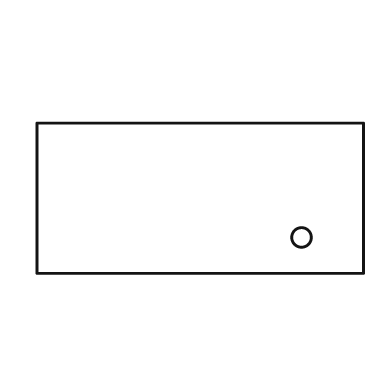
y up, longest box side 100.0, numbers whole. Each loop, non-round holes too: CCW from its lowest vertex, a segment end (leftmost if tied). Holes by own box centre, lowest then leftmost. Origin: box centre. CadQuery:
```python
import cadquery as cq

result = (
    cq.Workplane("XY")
    .moveTo(-50.0, -23.0)
    .lineTo(50.0, -23.0)
    .lineTo(50.0, 23.0)
    .lineTo(-50.0, 23.0)
    .close()
    .moveTo(31.0, -12.0)
    .circle(3.0)
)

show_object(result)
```